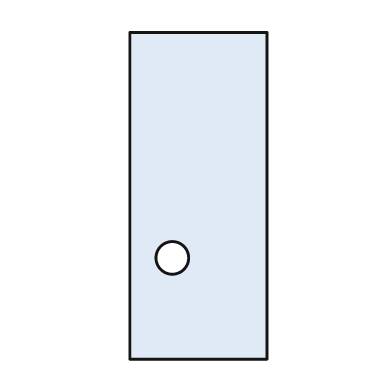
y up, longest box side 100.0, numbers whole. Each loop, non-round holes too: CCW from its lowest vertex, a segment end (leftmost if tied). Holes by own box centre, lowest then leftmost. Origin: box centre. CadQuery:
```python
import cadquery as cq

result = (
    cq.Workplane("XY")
    .moveTo(-21.0, -50.0)
    .lineTo(21.0, -50.0)
    .lineTo(21.0, 50.0)
    .lineTo(-21.0, 50.0)
    .close()
    .moveTo(-8.0, -19.0)
    .circle(5.0)
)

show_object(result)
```